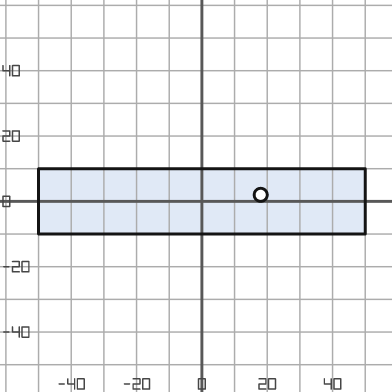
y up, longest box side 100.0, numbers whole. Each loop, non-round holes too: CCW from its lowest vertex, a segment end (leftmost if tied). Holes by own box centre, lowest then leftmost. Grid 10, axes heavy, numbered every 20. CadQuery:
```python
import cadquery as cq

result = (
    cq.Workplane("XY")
    .moveTo(-50.0, -10.0)
    .lineTo(50.0, -10.0)
    .lineTo(50.0, 10.0)
    .lineTo(-50.0, 10.0)
    .close()
    .moveTo(18.0, 2.0)
    .circle(2.0)
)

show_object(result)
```